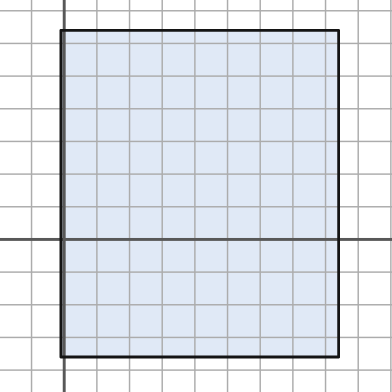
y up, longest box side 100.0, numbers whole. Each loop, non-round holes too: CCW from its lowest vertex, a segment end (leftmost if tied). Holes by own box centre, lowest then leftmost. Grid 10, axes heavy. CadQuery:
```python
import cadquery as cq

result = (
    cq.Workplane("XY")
    .moveTo(-1.0, -36.0)
    .lineTo(84.0, -36.0)
    .lineTo(84.0, 64.0)
    .lineTo(-1.0, 64.0)
    .close()
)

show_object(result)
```